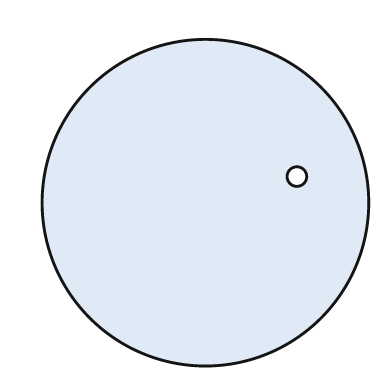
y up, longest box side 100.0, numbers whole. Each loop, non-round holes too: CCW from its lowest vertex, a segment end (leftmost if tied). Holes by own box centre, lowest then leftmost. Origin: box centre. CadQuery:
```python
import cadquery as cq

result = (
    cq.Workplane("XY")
    .moveTo(0.0, 0.0)
    .circle(50.0)
    .moveTo(28.0, 8.0)
    .circle(3.0)
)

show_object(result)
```